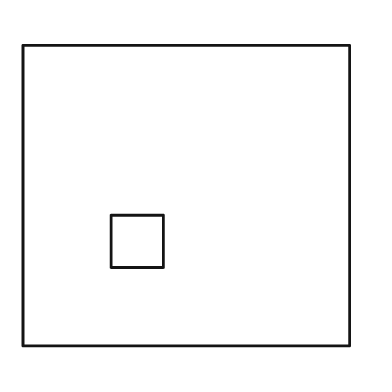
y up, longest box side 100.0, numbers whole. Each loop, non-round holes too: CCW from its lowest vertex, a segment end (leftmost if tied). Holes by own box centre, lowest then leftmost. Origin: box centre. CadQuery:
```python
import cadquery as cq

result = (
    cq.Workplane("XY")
    .moveTo(-50.0, -46.0)
    .lineTo(50.0, -46.0)
    .lineTo(50.0, 46.0)
    .lineTo(-50.0, 46.0)
    .close()
    .moveTo(-23.0, -22.0)
    .lineTo(-7.0, -22.0)
    .lineTo(-7.0, -6.0)
    .lineTo(-23.0, -6.0)
    .close()
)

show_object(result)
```